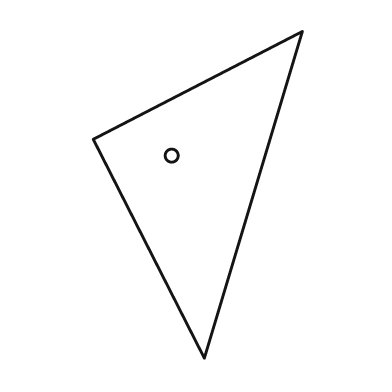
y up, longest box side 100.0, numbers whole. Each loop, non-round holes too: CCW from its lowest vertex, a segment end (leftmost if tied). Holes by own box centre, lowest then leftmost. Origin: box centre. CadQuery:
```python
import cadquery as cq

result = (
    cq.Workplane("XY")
    .moveTo(2.0, -50.0)
    .lineTo(32.0, 50.0)
    .lineTo(-32.0, 17.0)
    .close()
    .moveTo(-8.0, 12.0)
    .circle(2.0)
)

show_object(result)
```